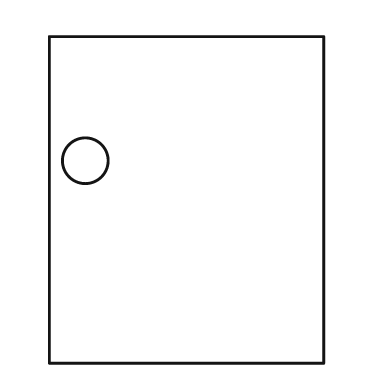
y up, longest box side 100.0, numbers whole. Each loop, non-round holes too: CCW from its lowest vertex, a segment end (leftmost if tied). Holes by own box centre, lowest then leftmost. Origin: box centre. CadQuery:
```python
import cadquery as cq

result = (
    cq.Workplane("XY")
    .moveTo(-42.0, -50.0)
    .lineTo(42.0, -50.0)
    .lineTo(42.0, 50.0)
    .lineTo(-42.0, 50.0)
    .close()
    .moveTo(-31.0, 12.0)
    .circle(7.0)
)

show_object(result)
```